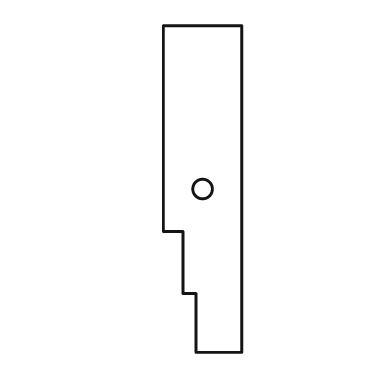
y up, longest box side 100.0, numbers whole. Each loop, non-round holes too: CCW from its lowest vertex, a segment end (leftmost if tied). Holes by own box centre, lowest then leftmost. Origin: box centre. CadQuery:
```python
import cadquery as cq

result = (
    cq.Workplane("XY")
    .moveTo(-2.0, -50.0)
    .lineTo(12.0, -50.0)
    .lineTo(12.0, 50.0)
    .lineTo(-12.0, 50.0)
    .lineTo(-12.0, -13.0)
    .lineTo(-6.0, -13.0)
    .lineTo(-6.0, -32.0)
    .lineTo(-2.0, -32.0)
    .close()
    .moveTo(0.0, 0.0)
    .circle(3.0)
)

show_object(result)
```